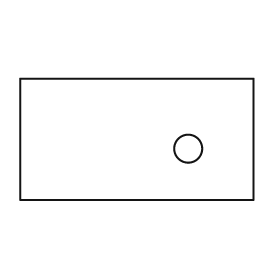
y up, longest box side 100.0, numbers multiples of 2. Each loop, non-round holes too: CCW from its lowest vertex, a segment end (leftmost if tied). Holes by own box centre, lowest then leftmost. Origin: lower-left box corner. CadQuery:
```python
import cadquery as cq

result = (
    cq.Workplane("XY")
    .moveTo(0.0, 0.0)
    .lineTo(100.0, 0.0)
    .lineTo(100.0, 52.0)
    .lineTo(0.0, 52.0)
    .close()
    .moveTo(72.0, 22.0)
    .circle(6.0)
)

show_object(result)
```